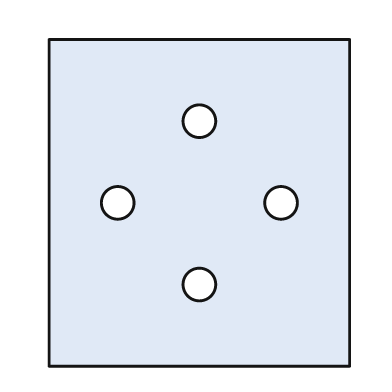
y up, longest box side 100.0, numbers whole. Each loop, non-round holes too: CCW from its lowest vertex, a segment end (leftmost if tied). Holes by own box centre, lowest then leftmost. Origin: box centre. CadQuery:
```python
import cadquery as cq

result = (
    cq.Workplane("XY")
    .moveTo(-46.0, -50.0)
    .lineTo(46.0, -50.0)
    .lineTo(46.0, 50.0)
    .lineTo(-46.0, 50.0)
    .close()
    .moveTo(0.0, -25.0)
    .circle(5.0)
    .moveTo(-25.0, 0.0)
    .circle(5.0)
    .moveTo(25.0, 0.0)
    .circle(5.0)
    .moveTo(0.0, 25.0)
    .circle(5.0)
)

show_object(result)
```